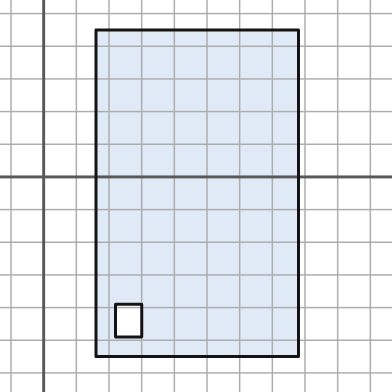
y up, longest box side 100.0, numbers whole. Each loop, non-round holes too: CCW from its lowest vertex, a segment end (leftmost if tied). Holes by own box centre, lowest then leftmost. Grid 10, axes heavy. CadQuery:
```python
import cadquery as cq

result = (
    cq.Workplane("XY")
    .moveTo(16.0, -55.0)
    .lineTo(78.0, -55.0)
    .lineTo(78.0, 45.0)
    .lineTo(16.0, 45.0)
    .close()
    .moveTo(22.0, -49.0)
    .lineTo(30.0, -49.0)
    .lineTo(30.0, -39.0)
    .lineTo(22.0, -39.0)
    .close()
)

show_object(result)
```